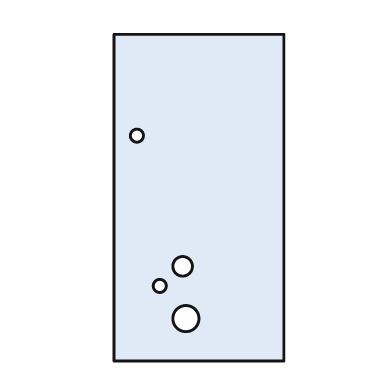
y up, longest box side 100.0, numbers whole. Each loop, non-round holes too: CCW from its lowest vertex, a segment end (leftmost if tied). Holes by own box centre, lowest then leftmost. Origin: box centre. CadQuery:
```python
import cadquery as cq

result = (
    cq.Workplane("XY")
    .moveTo(-26.0, -50.0)
    .lineTo(26.0, -50.0)
    .lineTo(26.0, 50.0)
    .lineTo(-26.0, 50.0)
    .close()
    .moveTo(-4.0, -37.0)
    .circle(4.0)
    .moveTo(-12.0, -27.0)
    .circle(2.0)
    .moveTo(-5.0, -21.0)
    .circle(3.0)
    .moveTo(-19.0, 19.0)
    .circle(2.0)
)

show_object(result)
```